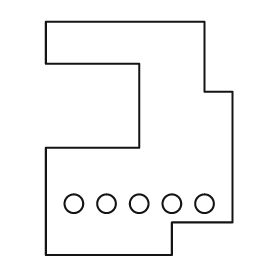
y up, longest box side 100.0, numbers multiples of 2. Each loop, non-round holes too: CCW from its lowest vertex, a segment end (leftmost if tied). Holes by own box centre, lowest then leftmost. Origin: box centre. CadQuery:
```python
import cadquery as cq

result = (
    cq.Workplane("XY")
    .moveTo(-40.0, -50.0)
    .lineTo(14.0, -50.0)
    .lineTo(14.0, -36.0)
    .lineTo(40.0, -36.0)
    .lineTo(40.0, 20.0)
    .lineTo(28.0, 20.0)
    .lineTo(28.0, 50.0)
    .lineTo(-40.0, 50.0)
    .lineTo(-40.0, 32.0)
    .lineTo(0.0, 32.0)
    .lineTo(0.0, -4.0)
    .lineTo(-40.0, -4.0)
    .close()
    .moveTo(-28.0, -28.0)
    .circle(4.0)
    .moveTo(-14.0, -28.0)
    .circle(4.0)
    .moveTo(0.0, -28.0)
    .circle(4.0)
    .moveTo(14.0, -28.0)
    .circle(4.0)
    .moveTo(28.0, -28.0)
    .circle(4.0)
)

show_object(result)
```